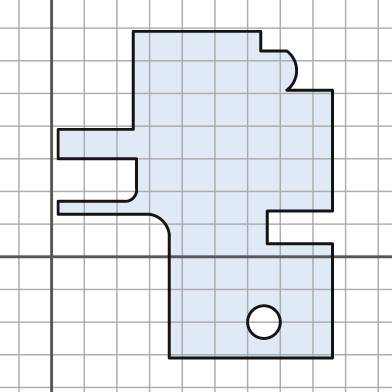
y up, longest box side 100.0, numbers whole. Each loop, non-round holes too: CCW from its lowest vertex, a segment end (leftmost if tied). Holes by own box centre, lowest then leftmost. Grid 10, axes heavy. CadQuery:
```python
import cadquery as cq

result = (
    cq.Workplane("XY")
    .moveTo(36.0, -31.0)
    .lineTo(86.0, -31.0)
    .lineTo(86.0, 4.0)
    .lineTo(66.0, 4.0)
    .lineTo(66.0, 14.0)
    .lineTo(86.0, 14.0)
    .lineTo(86.0, 51.0)
    .lineTo(72.0, 51.0)
    .threePointArc((75.0, 57.0), (72.0, 63.0))
    .lineTo(64.0, 63.0)
    .lineTo(64.0, 69.0)
    .lineTo(25.0, 69.0)
    .lineTo(25.0, 39.0)
    .lineTo(2.0, 39.0)
    .lineTo(2.0, 30.0)
    .lineTo(26.0, 30.0)
    .lineTo(26.0, 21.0)
    .threePointArc((25.0, 18.0), (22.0, 17.0))
    .lineTo(2.0, 17.0)
    .lineTo(2.0, 13.0)
    .lineTo(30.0, 13.0)
    .threePointArc((34.0, 11.0), (36.0, 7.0))
    .close()
    .moveTo(65.0, -20.0)
    .circle(5.0)
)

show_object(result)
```